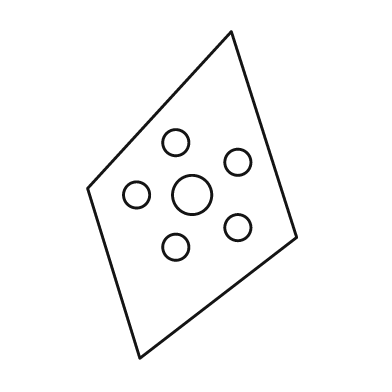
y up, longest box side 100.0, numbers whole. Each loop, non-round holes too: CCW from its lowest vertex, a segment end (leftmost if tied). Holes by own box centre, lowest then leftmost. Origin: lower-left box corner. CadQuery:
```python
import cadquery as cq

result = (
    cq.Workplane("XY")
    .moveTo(16.0, 0.0)
    .lineTo(64.0, 37.0)
    .lineTo(44.0, 100.0)
    .lineTo(0.0, 52.0)
    .close()
    .moveTo(27.0, 34.0)
    .circle(4.0)
    .moveTo(46.0, 40.0)
    .circle(4.0)
    .moveTo(15.0, 50.0)
    .circle(4.0)
    .moveTo(32.0, 50.0)
    .circle(6.0)
    .moveTo(46.0, 60.0)
    .circle(4.0)
    .moveTo(27.0, 66.0)
    .circle(4.0)
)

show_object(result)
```